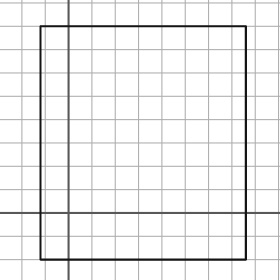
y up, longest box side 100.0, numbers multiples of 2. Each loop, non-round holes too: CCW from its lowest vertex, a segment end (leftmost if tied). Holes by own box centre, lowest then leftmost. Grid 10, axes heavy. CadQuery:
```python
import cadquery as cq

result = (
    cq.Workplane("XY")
    .moveTo(-12.0, -20.0)
    .lineTo(76.0, -20.0)
    .lineTo(76.0, 80.0)
    .lineTo(-12.0, 80.0)
    .close()
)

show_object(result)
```